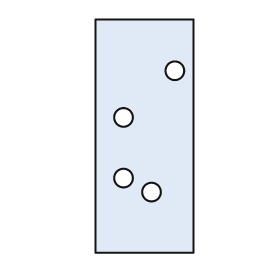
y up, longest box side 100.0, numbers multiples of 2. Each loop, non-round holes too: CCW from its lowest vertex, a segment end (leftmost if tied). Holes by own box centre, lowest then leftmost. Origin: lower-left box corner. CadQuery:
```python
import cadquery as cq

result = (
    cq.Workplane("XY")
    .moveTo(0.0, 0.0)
    .lineTo(42.0, 0.0)
    .lineTo(42.0, 100.0)
    .lineTo(0.0, 100.0)
    .close()
    .moveTo(24.0, 26.0)
    .circle(4.0)
    .moveTo(12.0, 32.0)
    .circle(4.0)
    .moveTo(12.0, 58.0)
    .circle(4.0)
    .moveTo(34.0, 78.0)
    .circle(4.0)
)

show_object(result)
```